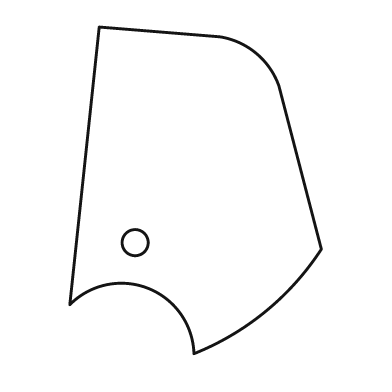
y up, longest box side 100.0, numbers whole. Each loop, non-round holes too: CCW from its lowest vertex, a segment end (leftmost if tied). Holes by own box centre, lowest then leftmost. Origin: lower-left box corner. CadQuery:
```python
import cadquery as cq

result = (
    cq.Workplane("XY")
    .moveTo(38.0, 0.0)
    .threePointArc((60.0, 13.0), (77.0, 32.0))
    .lineTo(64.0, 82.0)
    .threePointArc((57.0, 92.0), (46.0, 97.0))
    .lineTo(9.0, 100.0)
    .lineTo(0.0, 15.0)
    .threePointArc((24.0, 20.0), (38.0, 0.0))
    .close()
    .moveTo(20.0, 34.0)
    .circle(4.0)
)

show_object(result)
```